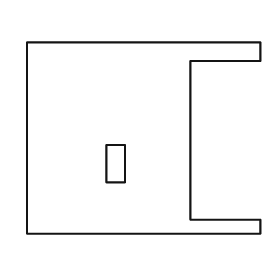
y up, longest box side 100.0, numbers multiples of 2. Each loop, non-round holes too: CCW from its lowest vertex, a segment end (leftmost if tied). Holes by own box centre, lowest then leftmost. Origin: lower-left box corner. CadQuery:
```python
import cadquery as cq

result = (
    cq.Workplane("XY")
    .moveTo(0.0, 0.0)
    .lineTo(100.0, 0.0)
    .lineTo(100.0, 6.0)
    .lineTo(70.0, 6.0)
    .lineTo(70.0, 74.0)
    .lineTo(100.0, 74.0)
    .lineTo(100.0, 82.0)
    .lineTo(0.0, 82.0)
    .close()
    .moveTo(34.0, 22.0)
    .lineTo(42.0, 22.0)
    .lineTo(42.0, 38.0)
    .lineTo(34.0, 38.0)
    .close()
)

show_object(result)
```